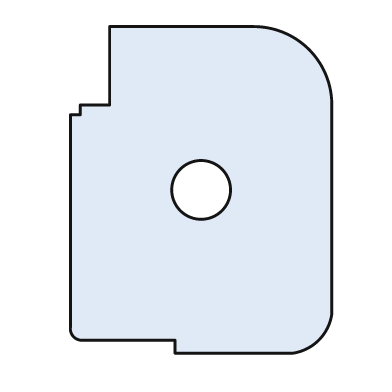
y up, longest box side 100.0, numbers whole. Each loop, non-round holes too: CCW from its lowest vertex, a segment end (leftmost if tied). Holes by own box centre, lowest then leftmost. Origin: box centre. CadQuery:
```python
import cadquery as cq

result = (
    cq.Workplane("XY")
    .moveTo(-8.0, -50.0)
    .lineTo(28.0, -50.0)
    .threePointArc((36.0, -46.0), (40.0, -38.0))
    .lineTo(40.0, 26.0)
    .threePointArc((33.0, 43.0), (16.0, 50.0))
    .lineTo(-28.0, 50.0)
    .lineTo(-28.0, 26.0)
    .lineTo(-37.0, 26.0)
    .lineTo(-37.0, 23.0)
    .lineTo(-40.0, 23.0)
    .lineTo(-40.0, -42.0)
    .threePointArc((-39.0, -45.0), (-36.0, -46.0))
    .lineTo(-8.0, -46.0)
    .close()
    .moveTo(0.0, 0.0)
    .circle(9.0)
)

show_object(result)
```